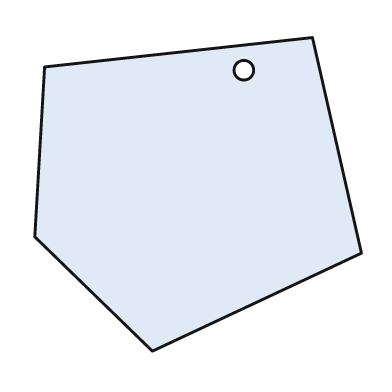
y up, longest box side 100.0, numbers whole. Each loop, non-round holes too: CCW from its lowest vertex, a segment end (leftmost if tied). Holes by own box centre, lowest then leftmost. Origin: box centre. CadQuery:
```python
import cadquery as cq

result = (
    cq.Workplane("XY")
    .moveTo(-14.0, -48.0)
    .lineTo(50.0, -18.0)
    .lineTo(35.0, 48.0)
    .lineTo(-47.0, 39.0)
    .lineTo(-50.0, -13.0)
    .close()
    .moveTo(14.0, 38.0)
    .circle(3.0)
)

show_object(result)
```